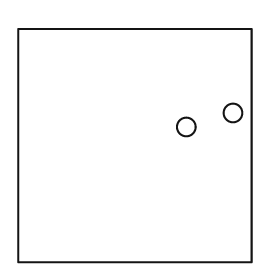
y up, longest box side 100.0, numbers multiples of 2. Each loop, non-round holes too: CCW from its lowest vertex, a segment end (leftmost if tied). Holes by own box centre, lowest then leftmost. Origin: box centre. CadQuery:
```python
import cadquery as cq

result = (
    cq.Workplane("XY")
    .moveTo(-50.0, -50.0)
    .lineTo(50.0, -50.0)
    .lineTo(50.0, 50.0)
    .lineTo(-50.0, 50.0)
    .close()
    .moveTo(22.0, 8.0)
    .circle(4.0)
    .moveTo(42.0, 14.0)
    .circle(4.0)
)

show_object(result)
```